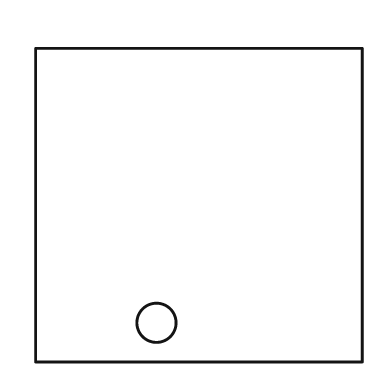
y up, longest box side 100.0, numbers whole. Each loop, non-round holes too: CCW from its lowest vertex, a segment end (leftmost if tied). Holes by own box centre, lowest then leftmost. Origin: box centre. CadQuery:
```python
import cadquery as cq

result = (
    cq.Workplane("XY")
    .moveTo(-50.0, -48.0)
    .lineTo(50.0, -48.0)
    .lineTo(50.0, 48.0)
    .lineTo(-50.0, 48.0)
    .close()
    .moveTo(-13.0, -36.0)
    .circle(6.0)
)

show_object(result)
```